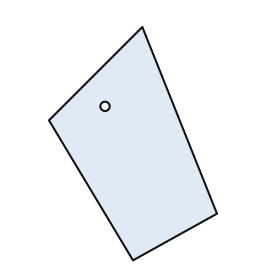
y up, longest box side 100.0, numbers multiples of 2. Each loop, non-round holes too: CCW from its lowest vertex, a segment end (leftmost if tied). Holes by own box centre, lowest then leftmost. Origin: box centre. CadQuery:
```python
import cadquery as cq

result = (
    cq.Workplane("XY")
    .moveTo(0.0, -50.0)
    .lineTo(36.0, -30.0)
    .lineTo(4.0, 50.0)
    .lineTo(-36.0, 10.0)
    .close()
    .moveTo(-12.0, 16.0)
    .circle(2.0)
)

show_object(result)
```